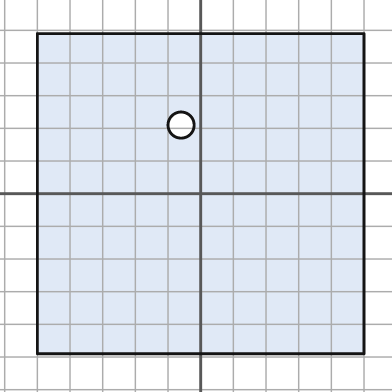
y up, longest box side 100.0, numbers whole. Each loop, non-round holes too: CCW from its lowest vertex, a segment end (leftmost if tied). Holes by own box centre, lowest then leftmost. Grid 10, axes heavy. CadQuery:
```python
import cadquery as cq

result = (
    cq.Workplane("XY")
    .moveTo(-50.0, -49.0)
    .lineTo(50.0, -49.0)
    .lineTo(50.0, 49.0)
    .lineTo(-50.0, 49.0)
    .close()
    .moveTo(-6.0, 21.0)
    .circle(4.0)
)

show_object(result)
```